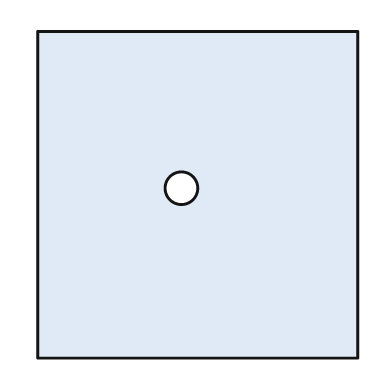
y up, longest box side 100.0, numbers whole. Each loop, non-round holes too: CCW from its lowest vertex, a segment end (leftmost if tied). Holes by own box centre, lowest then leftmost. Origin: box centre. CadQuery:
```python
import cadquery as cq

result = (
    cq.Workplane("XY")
    .moveTo(-49.0, -50.0)
    .lineTo(49.0, -50.0)
    .lineTo(49.0, 50.0)
    .lineTo(-49.0, 50.0)
    .close()
    .moveTo(-5.0, 2.0)
    .circle(5.0)
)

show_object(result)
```